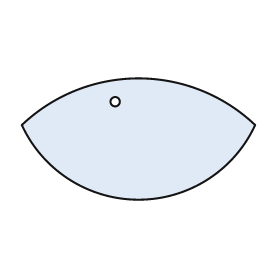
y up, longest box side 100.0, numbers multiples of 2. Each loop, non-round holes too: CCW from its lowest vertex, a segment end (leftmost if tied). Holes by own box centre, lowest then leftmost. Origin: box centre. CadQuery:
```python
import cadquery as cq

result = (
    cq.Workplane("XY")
    .moveTo(-50.0, 6.0)
    .threePointArc((0.0, -26.0), (50.0, 6.0))
    .threePointArc((0.0, 26.0), (-50.0, 6.0))
    .close()
    .moveTo(-10.0, 16.0)
    .circle(2.0)
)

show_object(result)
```